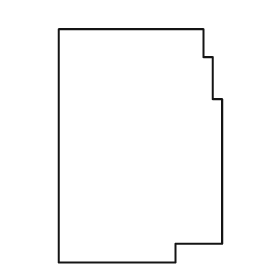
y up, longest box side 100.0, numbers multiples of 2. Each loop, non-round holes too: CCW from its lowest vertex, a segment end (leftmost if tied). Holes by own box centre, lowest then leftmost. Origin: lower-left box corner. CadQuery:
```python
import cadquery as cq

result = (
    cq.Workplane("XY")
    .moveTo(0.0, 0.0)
    .lineTo(50.0, 0.0)
    .lineTo(50.0, 8.0)
    .lineTo(70.0, 8.0)
    .lineTo(70.0, 70.0)
    .lineTo(66.0, 70.0)
    .lineTo(66.0, 88.0)
    .lineTo(62.0, 88.0)
    .lineTo(62.0, 100.0)
    .lineTo(0.0, 100.0)
    .close()
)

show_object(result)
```